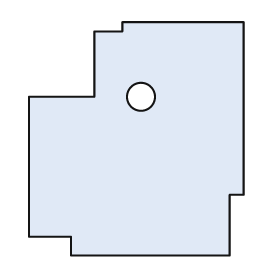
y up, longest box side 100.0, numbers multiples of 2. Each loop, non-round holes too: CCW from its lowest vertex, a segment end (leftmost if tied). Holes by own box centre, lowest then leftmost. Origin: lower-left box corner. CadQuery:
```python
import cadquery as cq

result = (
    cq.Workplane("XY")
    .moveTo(18.0, 0.0)
    .lineTo(86.0, 0.0)
    .lineTo(86.0, 26.0)
    .lineTo(92.0, 26.0)
    .lineTo(92.0, 100.0)
    .lineTo(40.0, 100.0)
    .lineTo(40.0, 96.0)
    .lineTo(28.0, 96.0)
    .lineTo(28.0, 68.0)
    .lineTo(0.0, 68.0)
    .lineTo(0.0, 8.0)
    .lineTo(18.0, 8.0)
    .close()
    .moveTo(48.0, 68.0)
    .circle(6.0)
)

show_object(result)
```